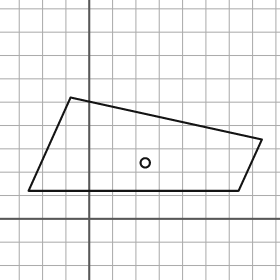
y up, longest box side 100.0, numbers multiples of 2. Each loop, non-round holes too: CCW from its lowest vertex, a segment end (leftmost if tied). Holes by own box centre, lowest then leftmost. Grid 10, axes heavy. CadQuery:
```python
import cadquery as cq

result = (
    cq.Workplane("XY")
    .moveTo(-26.0, 12.0)
    .lineTo(64.0, 12.0)
    .lineTo(74.0, 34.0)
    .lineTo(-8.0, 52.0)
    .close()
    .moveTo(24.0, 24.0)
    .circle(2.0)
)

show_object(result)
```